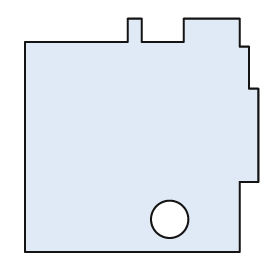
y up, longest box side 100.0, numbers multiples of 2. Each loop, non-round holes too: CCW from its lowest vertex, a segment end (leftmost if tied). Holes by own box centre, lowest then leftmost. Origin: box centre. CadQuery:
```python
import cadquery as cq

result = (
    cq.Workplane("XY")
    .moveTo(-50.0, -50.0)
    .lineTo(42.0, -50.0)
    .lineTo(42.0, -20.0)
    .lineTo(50.0, -20.0)
    .lineTo(50.0, 20.0)
    .lineTo(46.0, 20.0)
    .lineTo(46.0, 38.0)
    .lineTo(42.0, 38.0)
    .lineTo(42.0, 50.0)
    .lineTo(18.0, 50.0)
    .lineTo(18.0, 40.0)
    .lineTo(0.0, 40.0)
    .lineTo(0.0, 50.0)
    .lineTo(-6.0, 50.0)
    .lineTo(-6.0, 40.0)
    .lineTo(-50.0, 40.0)
    .close()
    .moveTo(12.0, -36.0)
    .circle(8.0)
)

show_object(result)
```